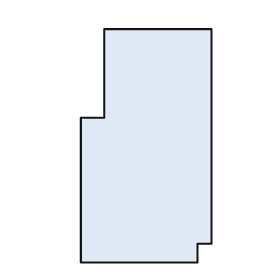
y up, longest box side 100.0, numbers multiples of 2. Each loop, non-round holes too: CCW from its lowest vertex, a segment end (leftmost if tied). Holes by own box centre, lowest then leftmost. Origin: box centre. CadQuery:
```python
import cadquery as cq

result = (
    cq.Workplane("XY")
    .moveTo(-28.0, -50.0)
    .lineTo(22.0, -50.0)
    .lineTo(22.0, -42.0)
    .lineTo(28.0, -42.0)
    .lineTo(28.0, 50.0)
    .lineTo(-18.0, 50.0)
    .lineTo(-18.0, 12.0)
    .lineTo(-28.0, 12.0)
    .close()
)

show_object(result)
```